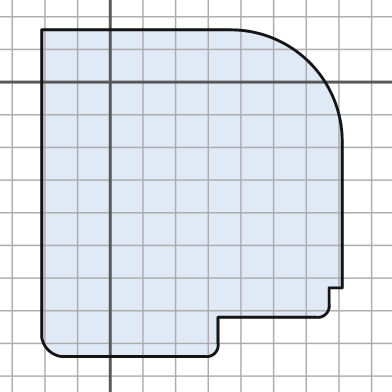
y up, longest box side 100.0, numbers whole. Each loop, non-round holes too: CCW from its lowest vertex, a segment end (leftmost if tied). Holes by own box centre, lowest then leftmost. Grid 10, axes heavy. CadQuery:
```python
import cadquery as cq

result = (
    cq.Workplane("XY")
    .moveTo(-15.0, -84.0)
    .lineTo(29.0, -84.0)
    .threePointArc((32.0, -83.0), (33.0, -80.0))
    .lineTo(33.0, -72.0)
    .lineTo(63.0, -72.0)
    .threePointArc((66.0, -71.0), (67.0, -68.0))
    .lineTo(67.0, -63.0)
    .lineTo(71.0, -63.0)
    .lineTo(71.0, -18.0)
    .threePointArc((61.0, 6.0), (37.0, 16.0))
    .lineTo(-21.0, 16.0)
    .lineTo(-21.0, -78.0)
    .threePointArc((-19.0, -82.0), (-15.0, -84.0))
    .close()
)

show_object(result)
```